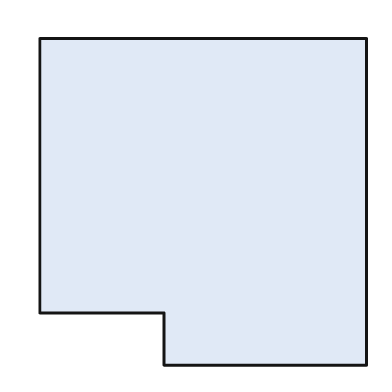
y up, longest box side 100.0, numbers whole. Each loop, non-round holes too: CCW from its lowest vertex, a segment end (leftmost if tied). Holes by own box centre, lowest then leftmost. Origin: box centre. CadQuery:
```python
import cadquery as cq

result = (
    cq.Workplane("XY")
    .moveTo(-12.0, -50.0)
    .lineTo(50.0, -50.0)
    .lineTo(50.0, 50.0)
    .lineTo(-50.0, 50.0)
    .lineTo(-50.0, -34.0)
    .lineTo(-12.0, -34.0)
    .close()
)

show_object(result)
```